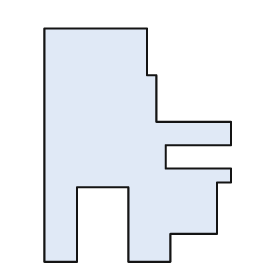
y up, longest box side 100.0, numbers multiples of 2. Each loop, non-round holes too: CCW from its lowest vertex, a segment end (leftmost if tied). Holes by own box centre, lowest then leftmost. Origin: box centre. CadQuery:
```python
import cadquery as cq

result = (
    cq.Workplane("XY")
    .moveTo(-40.0, -50.0)
    .lineTo(-26.0, -50.0)
    .lineTo(-26.0, -18.0)
    .lineTo(-4.0, -18.0)
    .lineTo(-4.0, -50.0)
    .lineTo(14.0, -50.0)
    .lineTo(14.0, -38.0)
    .lineTo(34.0, -38.0)
    .lineTo(34.0, -16.0)
    .lineTo(40.0, -16.0)
    .lineTo(40.0, -10.0)
    .lineTo(12.0, -10.0)
    .lineTo(12.0, 0.0)
    .lineTo(40.0, 0.0)
    .lineTo(40.0, 10.0)
    .lineTo(8.0, 10.0)
    .lineTo(8.0, 30.0)
    .lineTo(4.0, 30.0)
    .lineTo(4.0, 50.0)
    .lineTo(-40.0, 50.0)
    .close()
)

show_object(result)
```